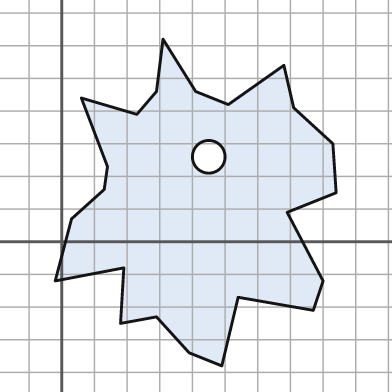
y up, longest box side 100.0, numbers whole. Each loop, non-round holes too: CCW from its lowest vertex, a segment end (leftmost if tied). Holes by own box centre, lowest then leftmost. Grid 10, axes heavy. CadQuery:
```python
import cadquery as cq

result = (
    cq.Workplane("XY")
    .moveTo(49.0, -38.0)
    .lineTo(54.0, -17.0)
    .lineTo(77.0, -21.0)
    .lineTo(80.0, -12.0)
    .lineTo(69.0, 9.0)
    .lineTo(84.0, 15.0)
    .lineTo(83.0, 30.0)
    .lineTo(71.0, 41.0)
    .lineTo(68.0, 54.0)
    .lineTo(51.0, 42.0)
    .lineTo(41.0, 46.0)
    .lineTo(31.0, 62.0)
    .lineTo(29.0, 46.0)
    .lineTo(23.0, 39.0)
    .lineTo(6.0, 44.0)
    .lineTo(14.0, 23.0)
    .lineTo(13.0, 16.0)
    .lineTo(3.0, 7.0)
    .lineTo(-2.0, -12.0)
    .lineTo(19.0, -8.0)
    .lineTo(18.0, -25.0)
    .lineTo(29.0, -23.0)
    .lineTo(39.0, -34.0)
    .close()
    .moveTo(45.0, 26.0)
    .circle(5.0)
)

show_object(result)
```